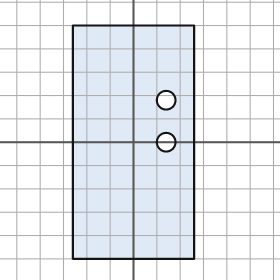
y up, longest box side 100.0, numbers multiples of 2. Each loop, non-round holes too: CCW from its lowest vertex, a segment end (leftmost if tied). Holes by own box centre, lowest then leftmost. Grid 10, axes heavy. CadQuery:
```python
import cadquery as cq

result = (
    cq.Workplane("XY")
    .moveTo(-26.0, -50.0)
    .lineTo(26.0, -50.0)
    .lineTo(26.0, 50.0)
    .lineTo(-26.0, 50.0)
    .close()
    .moveTo(14.0, 0.0)
    .circle(4.0)
    .moveTo(14.0, 18.0)
    .circle(4.0)
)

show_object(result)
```